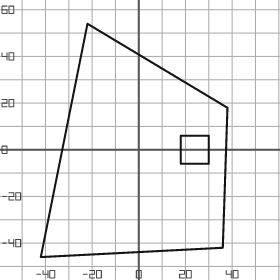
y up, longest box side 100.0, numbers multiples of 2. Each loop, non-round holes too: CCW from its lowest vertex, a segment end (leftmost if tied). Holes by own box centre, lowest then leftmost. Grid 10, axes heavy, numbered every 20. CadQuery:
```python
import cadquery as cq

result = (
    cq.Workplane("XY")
    .moveTo(-42.0, -46.0)
    .lineTo(36.0, -42.0)
    .lineTo(38.0, 18.0)
    .lineTo(-22.0, 54.0)
    .close()
    .moveTo(18.0, -6.0)
    .lineTo(30.0, -6.0)
    .lineTo(30.0, 6.0)
    .lineTo(18.0, 6.0)
    .close()
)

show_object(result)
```